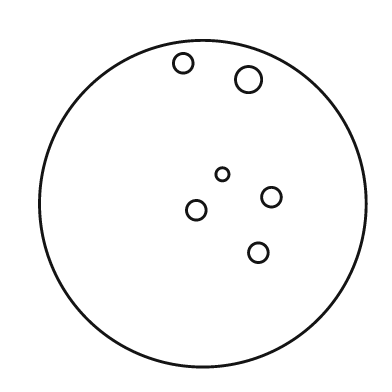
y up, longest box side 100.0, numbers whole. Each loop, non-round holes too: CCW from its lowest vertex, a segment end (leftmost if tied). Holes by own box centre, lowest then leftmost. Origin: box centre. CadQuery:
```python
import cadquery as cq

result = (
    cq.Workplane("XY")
    .moveTo(0.0, 0.0)
    .circle(50.0)
    .moveTo(17.0, -15.0)
    .circle(3.0)
    .moveTo(-2.0, -2.0)
    .circle(3.0)
    .moveTo(21.0, 2.0)
    .circle(3.0)
    .moveTo(6.0, 9.0)
    .circle(2.0)
    .moveTo(14.0, 38.0)
    .circle(4.0)
    .moveTo(-6.0, 43.0)
    .circle(3.0)
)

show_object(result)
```